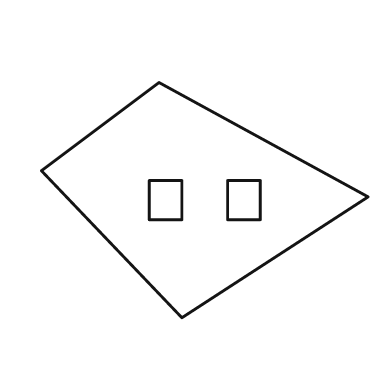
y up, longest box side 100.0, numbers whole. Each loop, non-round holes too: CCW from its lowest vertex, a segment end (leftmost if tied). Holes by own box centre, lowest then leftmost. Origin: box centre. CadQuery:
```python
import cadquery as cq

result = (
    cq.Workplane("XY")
    .moveTo(-7.0, -36.0)
    .lineTo(50.0, 1.0)
    .lineTo(-14.0, 36.0)
    .lineTo(-50.0, 9.0)
    .close()
    .moveTo(-17.0, -6.0)
    .lineTo(-7.0, -6.0)
    .lineTo(-7.0, 6.0)
    .lineTo(-17.0, 6.0)
    .close()
    .moveTo(7.0, -6.0)
    .lineTo(17.0, -6.0)
    .lineTo(17.0, 6.0)
    .lineTo(7.0, 6.0)
    .close()
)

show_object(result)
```